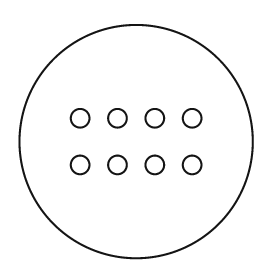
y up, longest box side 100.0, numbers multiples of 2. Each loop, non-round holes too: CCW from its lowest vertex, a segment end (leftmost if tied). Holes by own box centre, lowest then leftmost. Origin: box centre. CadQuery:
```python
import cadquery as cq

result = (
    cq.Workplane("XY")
    .moveTo(0.0, 0.0)
    .circle(50.0)
    .moveTo(-24.0, -10.0)
    .circle(4.0)
    .moveTo(-8.0, -10.0)
    .circle(4.0)
    .moveTo(8.0, -10.0)
    .circle(4.0)
    .moveTo(24.0, -10.0)
    .circle(4.0)
    .moveTo(-24.0, 10.0)
    .circle(4.0)
    .moveTo(-8.0, 10.0)
    .circle(4.0)
    .moveTo(8.0, 10.0)
    .circle(4.0)
    .moveTo(24.0, 10.0)
    .circle(4.0)
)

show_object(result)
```